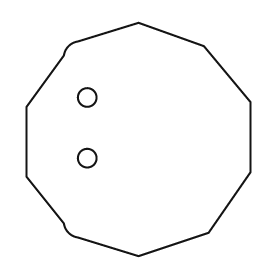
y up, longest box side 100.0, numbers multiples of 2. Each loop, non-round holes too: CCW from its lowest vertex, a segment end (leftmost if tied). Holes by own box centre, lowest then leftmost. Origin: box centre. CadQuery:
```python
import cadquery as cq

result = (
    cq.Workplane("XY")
    .moveTo(0.0, -50.0)
    .lineTo(30.0, -40.0)
    .lineTo(48.0, -14.0)
    .lineTo(48.0, 16.0)
    .lineTo(28.0, 40.0)
    .lineTo(0.0, 50.0)
    .lineTo(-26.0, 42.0)
    .threePointArc((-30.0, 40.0), (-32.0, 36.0))
    .lineTo(-48.0, 14.0)
    .lineTo(-48.0, -16.0)
    .lineTo(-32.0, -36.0)
    .threePointArc((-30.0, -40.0), (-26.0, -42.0))
    .close()
    .moveTo(-22.0, -8.0)
    .circle(4.0)
    .moveTo(-22.0, 18.0)
    .circle(4.0)
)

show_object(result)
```